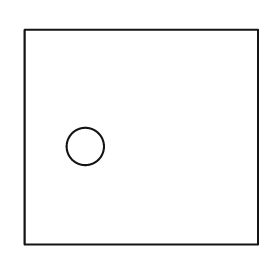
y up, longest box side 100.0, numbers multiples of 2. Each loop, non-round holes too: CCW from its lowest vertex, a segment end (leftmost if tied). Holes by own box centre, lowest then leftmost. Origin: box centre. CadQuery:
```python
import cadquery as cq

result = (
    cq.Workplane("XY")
    .moveTo(-50.0, -46.0)
    .lineTo(50.0, -46.0)
    .lineTo(50.0, 46.0)
    .lineTo(-50.0, 46.0)
    .close()
    .moveTo(-24.0, -4.0)
    .circle(8.0)
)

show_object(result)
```